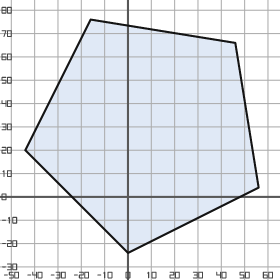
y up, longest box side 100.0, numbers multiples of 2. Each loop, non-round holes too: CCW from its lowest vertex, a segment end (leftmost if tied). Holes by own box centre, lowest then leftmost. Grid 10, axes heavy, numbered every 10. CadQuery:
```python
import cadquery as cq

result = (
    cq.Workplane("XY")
    .moveTo(0.0, -24.0)
    .lineTo(56.0, 4.0)
    .lineTo(46.0, 66.0)
    .lineTo(-16.0, 76.0)
    .lineTo(-44.0, 20.0)
    .close()
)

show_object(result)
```